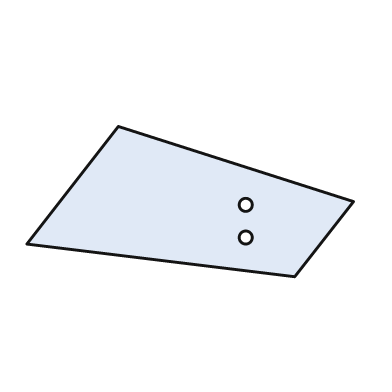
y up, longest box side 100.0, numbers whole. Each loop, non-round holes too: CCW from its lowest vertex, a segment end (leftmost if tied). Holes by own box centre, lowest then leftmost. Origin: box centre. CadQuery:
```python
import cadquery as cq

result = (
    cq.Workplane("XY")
    .moveTo(32.0, -23.0)
    .lineTo(50.0, 0.0)
    .lineTo(-22.0, 23.0)
    .lineTo(-50.0, -13.0)
    .close()
    .moveTo(17.0, -11.0)
    .circle(2.0)
    .moveTo(17.0, -1.0)
    .circle(2.0)
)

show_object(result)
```